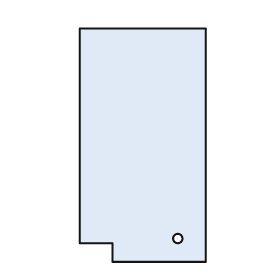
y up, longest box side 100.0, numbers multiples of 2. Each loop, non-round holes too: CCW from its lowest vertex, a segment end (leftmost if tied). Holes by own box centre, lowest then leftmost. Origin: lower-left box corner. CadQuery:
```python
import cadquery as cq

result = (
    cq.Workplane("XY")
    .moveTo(14.0, 0.0)
    .lineTo(54.0, 0.0)
    .lineTo(54.0, 100.0)
    .lineTo(0.0, 100.0)
    .lineTo(0.0, 8.0)
    .lineTo(14.0, 8.0)
    .close()
    .moveTo(42.0, 10.0)
    .circle(2.0)
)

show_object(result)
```